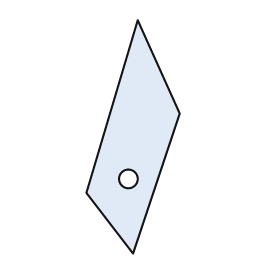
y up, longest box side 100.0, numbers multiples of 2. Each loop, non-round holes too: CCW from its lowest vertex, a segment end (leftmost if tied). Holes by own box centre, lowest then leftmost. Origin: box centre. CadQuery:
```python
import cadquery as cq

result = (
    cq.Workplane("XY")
    .moveTo(0.0, -50.0)
    .lineTo(20.0, 10.0)
    .lineTo(2.0, 50.0)
    .lineTo(-20.0, -24.0)
    .close()
    .moveTo(-2.0, -18.0)
    .circle(4.0)
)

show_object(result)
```